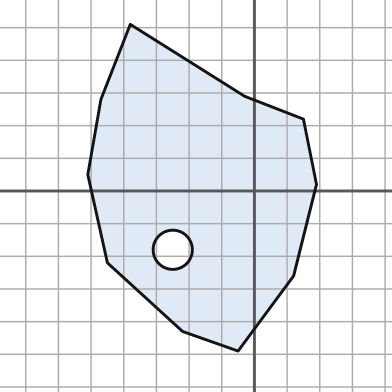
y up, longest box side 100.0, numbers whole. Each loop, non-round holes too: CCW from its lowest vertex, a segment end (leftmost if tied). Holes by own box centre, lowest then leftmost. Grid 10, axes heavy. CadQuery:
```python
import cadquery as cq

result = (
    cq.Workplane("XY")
    .moveTo(-5.0, -49.0)
    .lineTo(12.0, -26.0)
    .lineTo(19.0, 2.0)
    .lineTo(15.0, 22.0)
    .lineTo(-3.0, 29.0)
    .lineTo(-38.0, 51.0)
    .lineTo(-47.0, 28.0)
    .lineTo(-51.0, 5.0)
    .lineTo(-45.0, -22.0)
    .lineTo(-22.0, -43.0)
    .close()
    .moveTo(-25.0, -18.0)
    .circle(6.0)
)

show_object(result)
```